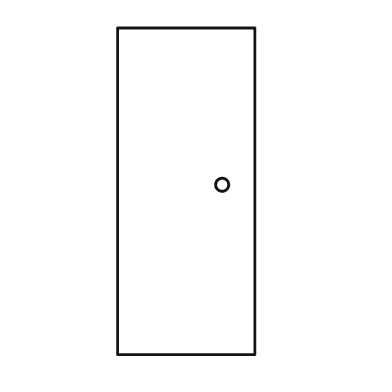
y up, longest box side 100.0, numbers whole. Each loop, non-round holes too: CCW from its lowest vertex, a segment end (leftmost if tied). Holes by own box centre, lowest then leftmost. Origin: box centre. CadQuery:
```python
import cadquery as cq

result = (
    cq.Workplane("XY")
    .moveTo(-21.0, -50.0)
    .lineTo(21.0, -50.0)
    .lineTo(21.0, 50.0)
    .lineTo(-21.0, 50.0)
    .close()
    .moveTo(11.0, 2.0)
    .circle(2.0)
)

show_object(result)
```